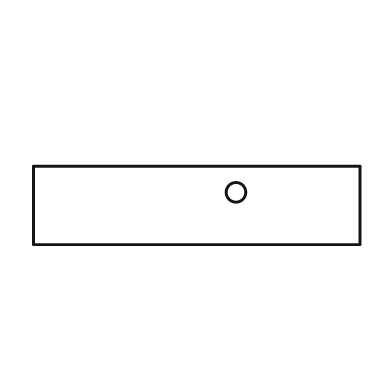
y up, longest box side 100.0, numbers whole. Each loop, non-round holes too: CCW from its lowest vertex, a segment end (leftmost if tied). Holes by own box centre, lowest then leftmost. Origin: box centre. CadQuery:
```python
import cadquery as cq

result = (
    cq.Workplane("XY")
    .moveTo(-50.0, -12.0)
    .lineTo(50.0, -12.0)
    .lineTo(50.0, 12.0)
    .lineTo(-50.0, 12.0)
    .close()
    .moveTo(12.0, 4.0)
    .circle(3.0)
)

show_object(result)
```